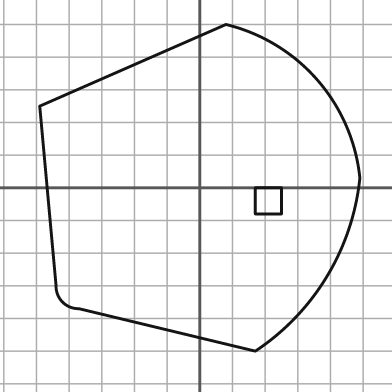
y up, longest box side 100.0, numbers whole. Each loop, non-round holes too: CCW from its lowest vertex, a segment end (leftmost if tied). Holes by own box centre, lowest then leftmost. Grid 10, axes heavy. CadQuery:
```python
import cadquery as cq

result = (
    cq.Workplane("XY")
    .moveTo(17.0, -50.0)
    .threePointArc((39.0, -27.0), (49.0, 3.0))
    .threePointArc((36.0, 33.0), (8.0, 50.0))
    .lineTo(-49.0, 25.0)
    .lineTo(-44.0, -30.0)
    .threePointArc((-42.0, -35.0), (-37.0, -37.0))
    .close()
    .moveTo(17.0, -8.0)
    .lineTo(25.0, -8.0)
    .lineTo(25.0, 0.0)
    .lineTo(17.0, 0.0)
    .close()
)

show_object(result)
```